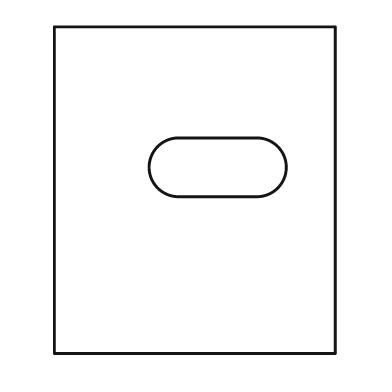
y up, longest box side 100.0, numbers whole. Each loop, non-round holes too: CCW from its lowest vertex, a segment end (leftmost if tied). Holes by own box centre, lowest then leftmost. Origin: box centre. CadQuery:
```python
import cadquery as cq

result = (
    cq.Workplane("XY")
    .moveTo(-43.0, -50.0)
    .lineTo(43.0, -50.0)
    .lineTo(43.0, 50.0)
    .lineTo(-43.0, 50.0)
    .close()
    .moveTo(-5.0, -2.0)
    .lineTo(19.0, -2.0)
    .threePointArc((28.0, 7.0), (19.0, 16.0))
    .lineTo(-5.0, 16.0)
    .threePointArc((-14.0, 7.0), (-5.0, -2.0))
    .close()
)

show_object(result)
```